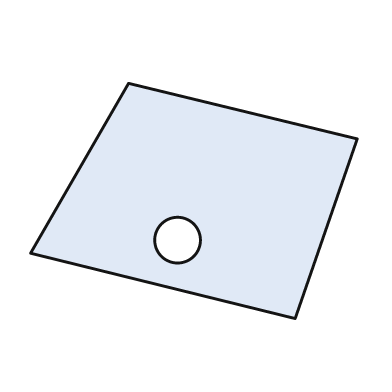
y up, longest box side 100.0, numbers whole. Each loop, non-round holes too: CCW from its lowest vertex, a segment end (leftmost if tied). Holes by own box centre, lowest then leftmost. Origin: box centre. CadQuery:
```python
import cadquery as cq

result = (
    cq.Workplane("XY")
    .moveTo(31.0, -36.0)
    .lineTo(50.0, 19.0)
    .lineTo(-20.0, 36.0)
    .lineTo(-50.0, -16.0)
    .close()
    .moveTo(-5.0, -12.0)
    .circle(7.0)
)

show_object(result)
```